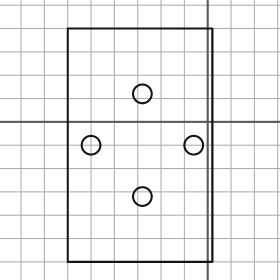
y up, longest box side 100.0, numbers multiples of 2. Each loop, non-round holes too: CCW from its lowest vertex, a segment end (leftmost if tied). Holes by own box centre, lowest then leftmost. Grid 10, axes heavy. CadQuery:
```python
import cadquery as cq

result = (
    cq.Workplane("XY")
    .moveTo(-60.0, -60.0)
    .lineTo(2.0, -60.0)
    .lineTo(2.0, 40.0)
    .lineTo(-60.0, 40.0)
    .close()
    .moveTo(-28.0, -32.0)
    .circle(4.0)
    .moveTo(-50.0, -10.0)
    .circle(4.0)
    .moveTo(-6.0, -10.0)
    .circle(4.0)
    .moveTo(-28.0, 12.0)
    .circle(4.0)
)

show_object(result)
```